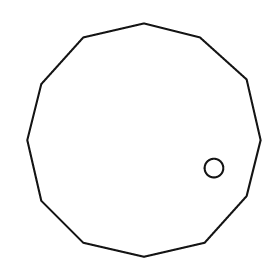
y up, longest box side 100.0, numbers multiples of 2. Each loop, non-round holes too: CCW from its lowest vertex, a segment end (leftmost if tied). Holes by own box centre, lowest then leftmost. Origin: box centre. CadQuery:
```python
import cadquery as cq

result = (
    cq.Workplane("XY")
    .moveTo(0.0, -50.0)
    .lineTo(26.0, -44.0)
    .lineTo(44.0, -24.0)
    .lineTo(50.0, 0.0)
    .lineTo(44.0, 26.0)
    .lineTo(24.0, 44.0)
    .lineTo(0.0, 50.0)
    .lineTo(-26.0, 44.0)
    .lineTo(-44.0, 24.0)
    .lineTo(-50.0, 0.0)
    .lineTo(-44.0, -26.0)
    .lineTo(-26.0, -44.0)
    .close()
    .moveTo(30.0, -12.0)
    .circle(4.0)
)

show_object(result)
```